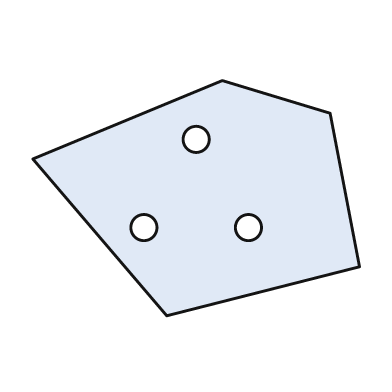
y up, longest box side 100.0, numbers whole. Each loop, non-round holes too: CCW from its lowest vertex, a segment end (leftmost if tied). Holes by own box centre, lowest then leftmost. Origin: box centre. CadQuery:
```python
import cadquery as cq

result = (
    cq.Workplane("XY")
    .moveTo(-9.0, -36.0)
    .lineTo(50.0, -21.0)
    .lineTo(41.0, 26.0)
    .lineTo(8.0, 36.0)
    .lineTo(-50.0, 12.0)
    .close()
    .moveTo(-16.0, -9.0)
    .circle(4.0)
    .moveTo(16.0, -9.0)
    .circle(4.0)
    .moveTo(0.0, 18.0)
    .circle(4.0)
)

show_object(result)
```